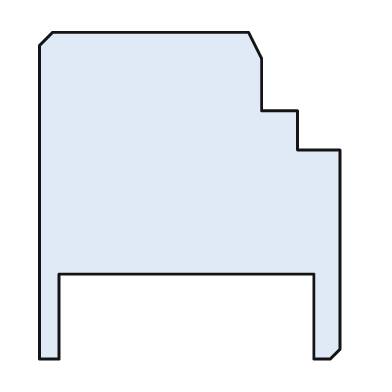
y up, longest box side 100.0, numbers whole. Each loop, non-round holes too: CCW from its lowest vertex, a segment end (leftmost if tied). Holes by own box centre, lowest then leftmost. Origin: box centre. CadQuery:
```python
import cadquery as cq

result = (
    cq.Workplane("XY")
    .moveTo(-46.0, -50.0)
    .lineTo(-40.0, -50.0)
    .lineTo(-40.0, -24.0)
    .lineTo(38.0, -24.0)
    .lineTo(38.0, -50.0)
    .lineTo(43.0, -50.0)
    .lineTo(46.0, -47.0)
    .lineTo(46.0, 14.0)
    .lineTo(33.0, 14.0)
    .lineTo(33.0, 26.0)
    .lineTo(22.0, 26.0)
    .lineTo(22.0, 42.0)
    .lineTo(18.0, 50.0)
    .lineTo(-42.0, 50.0)
    .lineTo(-46.0, 46.0)
    .close()
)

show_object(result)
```